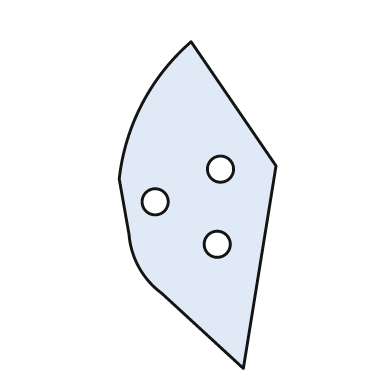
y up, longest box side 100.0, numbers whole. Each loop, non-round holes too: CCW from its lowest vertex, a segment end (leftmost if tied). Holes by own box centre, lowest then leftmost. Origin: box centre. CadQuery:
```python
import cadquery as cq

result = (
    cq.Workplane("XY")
    .moveTo(14.0, -50.0)
    .lineTo(24.0, 12.0)
    .lineTo(-2.0, 50.0)
    .threePointArc((-17.0, 31.0), (-24.0, 8.0))
    .lineTo(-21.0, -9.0)
    .threePointArc((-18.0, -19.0), (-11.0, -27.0))
    .close()
    .moveTo(6.0, -12.0)
    .circle(4.0)
    .moveTo(-13.0, 1.0)
    .circle(4.0)
    .moveTo(7.0, 11.0)
    .circle(4.0)
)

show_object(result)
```